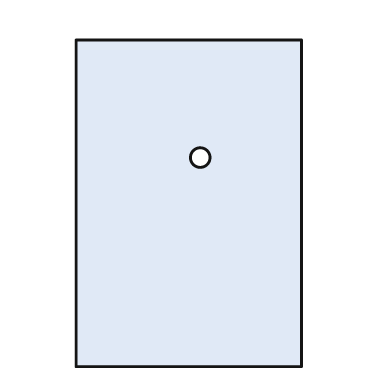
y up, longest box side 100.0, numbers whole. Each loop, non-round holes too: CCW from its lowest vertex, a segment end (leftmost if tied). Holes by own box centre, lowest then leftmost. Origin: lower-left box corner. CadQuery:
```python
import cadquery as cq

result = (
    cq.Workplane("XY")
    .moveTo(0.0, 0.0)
    .lineTo(69.0, 0.0)
    .lineTo(69.0, 100.0)
    .lineTo(0.0, 100.0)
    .close()
    .moveTo(38.0, 64.0)
    .circle(3.0)
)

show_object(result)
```